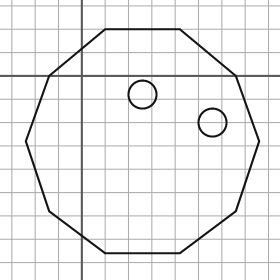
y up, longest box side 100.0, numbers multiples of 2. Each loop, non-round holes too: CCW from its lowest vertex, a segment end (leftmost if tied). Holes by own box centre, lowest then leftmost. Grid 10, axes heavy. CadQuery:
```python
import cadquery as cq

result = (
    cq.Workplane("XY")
    .moveTo(10.0, -76.0)
    .lineTo(42.0, -76.0)
    .lineTo(66.0, -58.0)
    .lineTo(76.0, -28.0)
    .lineTo(66.0, 0.0)
    .lineTo(42.0, 20.0)
    .lineTo(10.0, 20.0)
    .lineTo(-14.0, 0.0)
    .lineTo(-24.0, -28.0)
    .lineTo(-14.0, -58.0)
    .close()
    .moveTo(56.0, -20.0)
    .circle(6.0)
    .moveTo(26.0, -8.0)
    .circle(6.0)
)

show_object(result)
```